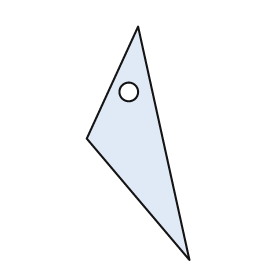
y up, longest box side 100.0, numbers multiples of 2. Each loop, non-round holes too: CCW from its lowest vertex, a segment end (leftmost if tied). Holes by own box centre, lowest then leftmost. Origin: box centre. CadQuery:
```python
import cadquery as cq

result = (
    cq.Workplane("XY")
    .moveTo(22.0, -50.0)
    .lineTo(0.0, 50.0)
    .lineTo(-22.0, 2.0)
    .close()
    .moveTo(-4.0, 22.0)
    .circle(4.0)
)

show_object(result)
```